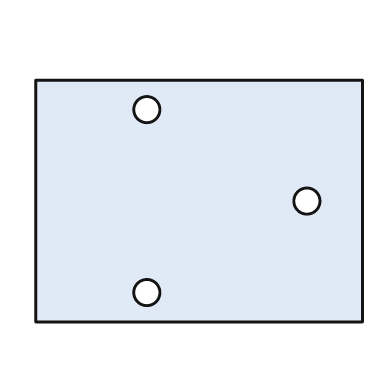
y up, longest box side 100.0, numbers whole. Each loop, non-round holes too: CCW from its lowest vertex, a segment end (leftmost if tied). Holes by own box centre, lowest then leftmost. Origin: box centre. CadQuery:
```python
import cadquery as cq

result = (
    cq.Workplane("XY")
    .moveTo(-50.0, -37.0)
    .lineTo(50.0, -37.0)
    .lineTo(50.0, 37.0)
    .lineTo(-50.0, 37.0)
    .close()
    .moveTo(-16.0, -28.0)
    .circle(4.0)
    .moveTo(33.0, 0.0)
    .circle(4.0)
    .moveTo(-16.0, 28.0)
    .circle(4.0)
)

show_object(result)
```